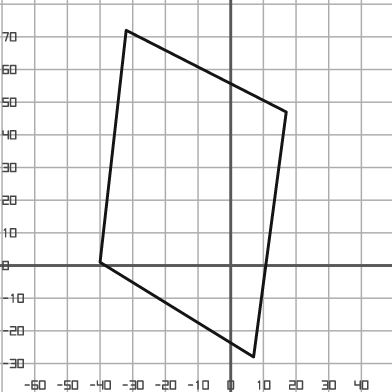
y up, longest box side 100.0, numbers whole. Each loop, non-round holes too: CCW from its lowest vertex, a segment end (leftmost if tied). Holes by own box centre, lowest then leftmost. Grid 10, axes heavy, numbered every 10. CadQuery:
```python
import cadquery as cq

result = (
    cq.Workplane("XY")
    .moveTo(7.0, -28.0)
    .lineTo(17.0, 47.0)
    .lineTo(-32.0, 72.0)
    .lineTo(-40.0, 1.0)
    .close()
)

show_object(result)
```